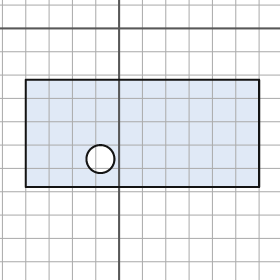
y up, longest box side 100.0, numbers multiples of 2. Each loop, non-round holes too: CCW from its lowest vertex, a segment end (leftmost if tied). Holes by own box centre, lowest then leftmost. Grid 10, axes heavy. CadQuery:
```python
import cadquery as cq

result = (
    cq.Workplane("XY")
    .moveTo(-40.0, -68.0)
    .lineTo(60.0, -68.0)
    .lineTo(60.0, -22.0)
    .lineTo(-40.0, -22.0)
    .close()
    .moveTo(-8.0, -56.0)
    .circle(6.0)
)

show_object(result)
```